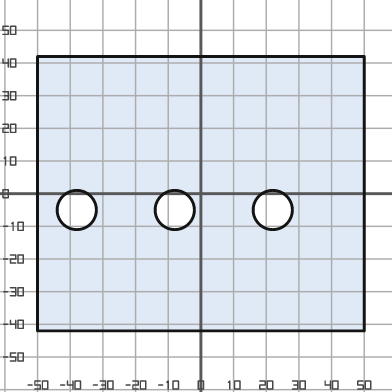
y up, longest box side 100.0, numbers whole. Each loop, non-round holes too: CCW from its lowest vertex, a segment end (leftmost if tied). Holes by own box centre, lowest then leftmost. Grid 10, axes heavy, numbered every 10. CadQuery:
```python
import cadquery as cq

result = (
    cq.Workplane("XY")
    .moveTo(-50.0, -42.0)
    .lineTo(50.0, -42.0)
    .lineTo(50.0, 42.0)
    .lineTo(-50.0, 42.0)
    .close()
    .moveTo(-38.0, -5.0)
    .circle(6.0)
    .moveTo(-8.0, -5.0)
    .circle(6.0)
    .moveTo(22.0, -5.0)
    .circle(6.0)
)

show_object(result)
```